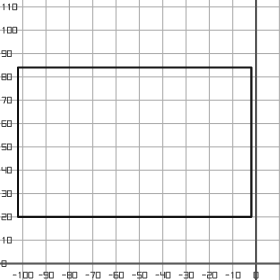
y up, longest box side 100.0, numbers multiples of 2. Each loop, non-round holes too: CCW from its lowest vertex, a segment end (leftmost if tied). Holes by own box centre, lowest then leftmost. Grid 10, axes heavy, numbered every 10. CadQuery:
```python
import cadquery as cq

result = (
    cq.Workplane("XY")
    .moveTo(-102.0, 20.0)
    .lineTo(-2.0, 20.0)
    .lineTo(-2.0, 84.0)
    .lineTo(-102.0, 84.0)
    .close()
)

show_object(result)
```